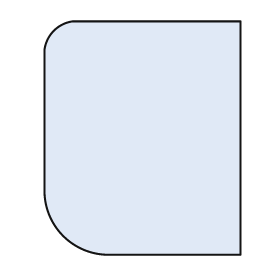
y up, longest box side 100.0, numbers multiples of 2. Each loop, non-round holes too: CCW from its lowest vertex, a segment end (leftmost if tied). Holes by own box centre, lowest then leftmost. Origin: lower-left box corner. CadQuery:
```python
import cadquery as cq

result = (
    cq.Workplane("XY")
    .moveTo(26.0, 0.0)
    .lineTo(84.0, 0.0)
    .lineTo(84.0, 100.0)
    .lineTo(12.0, 100.0)
    .threePointArc((4.0, 96.0), (0.0, 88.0))
    .lineTo(0.0, 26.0)
    .threePointArc((8.0, 8.0), (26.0, 0.0))
    .close()
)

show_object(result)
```